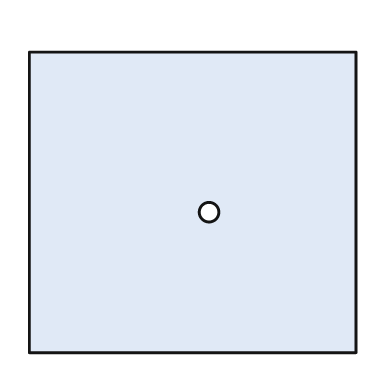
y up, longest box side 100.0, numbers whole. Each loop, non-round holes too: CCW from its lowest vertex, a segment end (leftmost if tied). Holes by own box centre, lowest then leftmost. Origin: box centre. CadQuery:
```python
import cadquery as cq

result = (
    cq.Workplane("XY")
    .moveTo(-50.0, -46.0)
    .lineTo(50.0, -46.0)
    .lineTo(50.0, 46.0)
    .lineTo(-50.0, 46.0)
    .close()
    .moveTo(5.0, -3.0)
    .circle(3.0)
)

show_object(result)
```